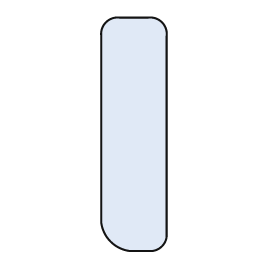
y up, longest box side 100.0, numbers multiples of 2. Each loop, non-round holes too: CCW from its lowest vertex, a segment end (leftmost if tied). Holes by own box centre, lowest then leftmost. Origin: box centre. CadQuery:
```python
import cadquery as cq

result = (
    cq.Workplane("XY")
    .moveTo(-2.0, -50.0)
    .lineTo(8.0, -50.0)
    .threePointArc((12.0, -48.0), (14.0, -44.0))
    .lineTo(14.0, 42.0)
    .threePointArc((12.0, 48.0), (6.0, 50.0))
    .lineTo(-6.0, 50.0)
    .threePointArc((-12.0, 48.0), (-14.0, 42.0))
    .lineTo(-14.0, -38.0)
    .threePointArc((-10.0, -46.0), (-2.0, -50.0))
    .close()
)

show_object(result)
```